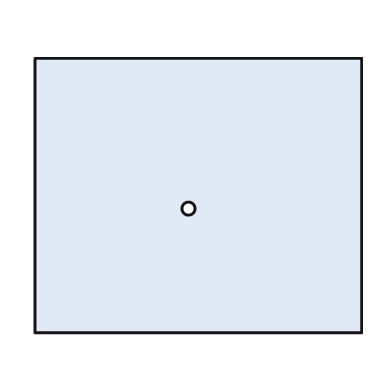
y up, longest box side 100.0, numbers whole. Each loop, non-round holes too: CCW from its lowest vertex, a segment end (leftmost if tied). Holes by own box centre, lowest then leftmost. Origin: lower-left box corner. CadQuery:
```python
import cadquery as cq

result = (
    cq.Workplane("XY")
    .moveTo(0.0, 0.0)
    .lineTo(100.0, 0.0)
    .lineTo(100.0, 84.0)
    .lineTo(0.0, 84.0)
    .close()
    .moveTo(47.0, 38.0)
    .circle(2.0)
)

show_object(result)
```